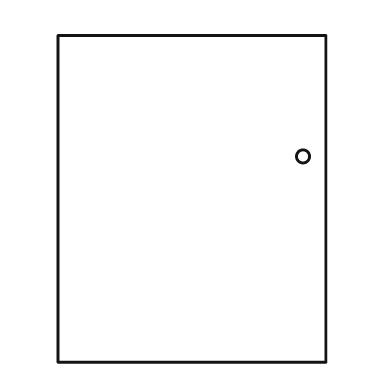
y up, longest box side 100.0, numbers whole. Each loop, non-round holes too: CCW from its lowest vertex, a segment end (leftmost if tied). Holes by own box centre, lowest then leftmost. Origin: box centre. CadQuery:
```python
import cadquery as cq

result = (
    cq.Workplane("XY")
    .moveTo(-41.0, -50.0)
    .lineTo(41.0, -50.0)
    .lineTo(41.0, 50.0)
    .lineTo(-41.0, 50.0)
    .close()
    .moveTo(34.0, 13.0)
    .circle(2.0)
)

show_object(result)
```